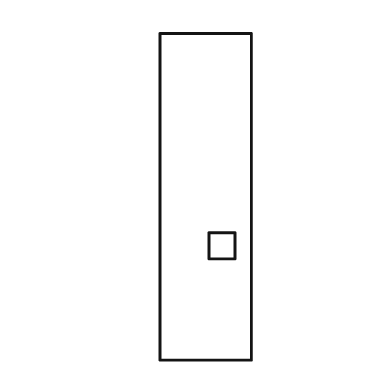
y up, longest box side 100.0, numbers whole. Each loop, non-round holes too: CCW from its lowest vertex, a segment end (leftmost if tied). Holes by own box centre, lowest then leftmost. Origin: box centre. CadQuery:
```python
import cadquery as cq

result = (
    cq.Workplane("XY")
    .moveTo(-14.0, -50.0)
    .lineTo(14.0, -50.0)
    .lineTo(14.0, 50.0)
    .lineTo(-14.0, 50.0)
    .close()
    .moveTo(1.0, -19.0)
    .lineTo(9.0, -19.0)
    .lineTo(9.0, -11.0)
    .lineTo(1.0, -11.0)
    .close()
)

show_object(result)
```